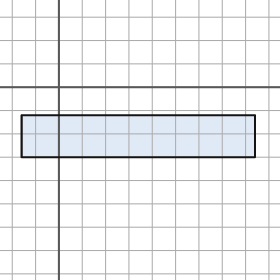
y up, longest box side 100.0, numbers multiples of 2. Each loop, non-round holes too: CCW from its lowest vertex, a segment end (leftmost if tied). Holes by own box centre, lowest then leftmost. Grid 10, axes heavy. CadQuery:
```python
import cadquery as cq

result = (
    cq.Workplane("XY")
    .moveTo(-16.0, -30.0)
    .lineTo(84.0, -30.0)
    .lineTo(84.0, -12.0)
    .lineTo(-16.0, -12.0)
    .close()
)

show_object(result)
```